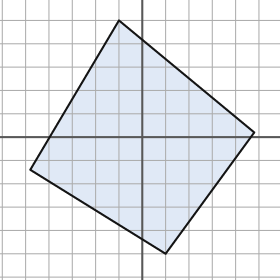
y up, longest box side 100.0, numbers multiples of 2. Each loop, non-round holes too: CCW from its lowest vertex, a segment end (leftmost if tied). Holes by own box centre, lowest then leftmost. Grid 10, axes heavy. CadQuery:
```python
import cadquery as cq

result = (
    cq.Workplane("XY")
    .moveTo(10.0, -50.0)
    .lineTo(48.0, 2.0)
    .lineTo(-10.0, 50.0)
    .lineTo(-48.0, -14.0)
    .close()
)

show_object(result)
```